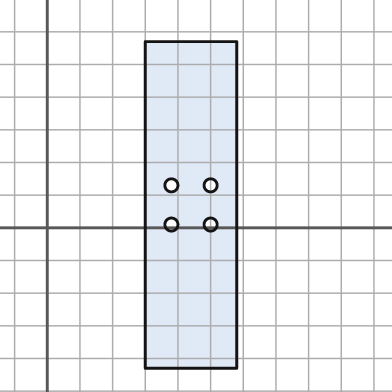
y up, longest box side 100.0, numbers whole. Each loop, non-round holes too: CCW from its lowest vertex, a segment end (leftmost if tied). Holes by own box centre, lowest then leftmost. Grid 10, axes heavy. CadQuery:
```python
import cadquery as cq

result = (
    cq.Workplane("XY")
    .moveTo(30.0, -43.0)
    .lineTo(58.0, -43.0)
    .lineTo(58.0, 57.0)
    .lineTo(30.0, 57.0)
    .close()
    .moveTo(38.0, 1.0)
    .circle(2.0)
    .moveTo(50.0, 1.0)
    .circle(2.0)
    .moveTo(38.0, 13.0)
    .circle(2.0)
    .moveTo(50.0, 13.0)
    .circle(2.0)
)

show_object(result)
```